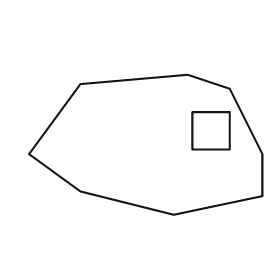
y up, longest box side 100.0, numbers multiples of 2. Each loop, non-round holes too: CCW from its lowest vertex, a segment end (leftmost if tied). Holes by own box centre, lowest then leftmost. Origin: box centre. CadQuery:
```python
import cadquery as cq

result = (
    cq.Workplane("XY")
    .moveTo(12.0, -30.0)
    .lineTo(50.0, -22.0)
    .lineTo(50.0, -4.0)
    .lineTo(36.0, 24.0)
    .lineTo(18.0, 30.0)
    .lineTo(-28.0, 26.0)
    .lineTo(-50.0, -4.0)
    .lineTo(-28.0, -20.0)
    .close()
    .moveTo(20.0, -2.0)
    .lineTo(36.0, -2.0)
    .lineTo(36.0, 14.0)
    .lineTo(20.0, 14.0)
    .close()
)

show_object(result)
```